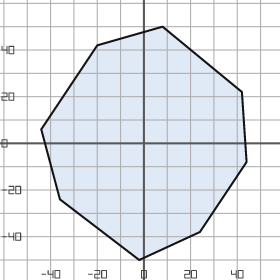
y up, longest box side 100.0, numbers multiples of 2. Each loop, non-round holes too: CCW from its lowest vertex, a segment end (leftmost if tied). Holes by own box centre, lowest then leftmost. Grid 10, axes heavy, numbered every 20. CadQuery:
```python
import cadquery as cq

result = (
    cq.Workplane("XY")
    .moveTo(-2.0, -50.0)
    .lineTo(24.0, -38.0)
    .lineTo(44.0, -8.0)
    .lineTo(42.0, 22.0)
    .lineTo(8.0, 50.0)
    .lineTo(-20.0, 42.0)
    .lineTo(-44.0, 6.0)
    .lineTo(-36.0, -24.0)
    .close()
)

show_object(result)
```